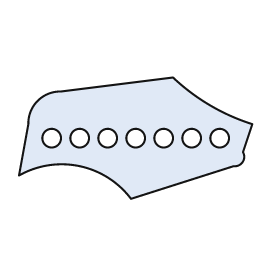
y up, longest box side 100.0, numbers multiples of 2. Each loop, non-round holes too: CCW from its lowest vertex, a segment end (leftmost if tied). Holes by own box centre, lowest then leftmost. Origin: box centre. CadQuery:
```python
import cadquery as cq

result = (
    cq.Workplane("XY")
    .moveTo(-2.0, -26.0)
    .lineTo(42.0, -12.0)
    .threePointArc((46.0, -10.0), (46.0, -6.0))
    .lineTo(50.0, 6.0)
    .threePointArc((32.0, 14.0), (16.0, 26.0))
    .lineTo(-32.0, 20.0)
    .threePointArc((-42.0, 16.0), (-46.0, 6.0))
    .lineTo(-50.0, -16.0)
    .threePointArc((-24.0, -12.0), (-2.0, -26.0))
    .close()
    .moveTo(-36.0, 0.0)
    .circle(4.0)
    .moveTo(-24.0, 0.0)
    .circle(4.0)
    .moveTo(-12.0, 0.0)
    .circle(4.0)
    .moveTo(0.0, 0.0)
    .circle(4.0)
    .moveTo(12.0, 0.0)
    .circle(4.0)
    .moveTo(24.0, 0.0)
    .circle(4.0)
    .moveTo(36.0, 0.0)
    .circle(4.0)
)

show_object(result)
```